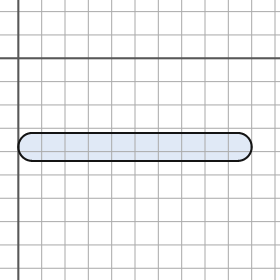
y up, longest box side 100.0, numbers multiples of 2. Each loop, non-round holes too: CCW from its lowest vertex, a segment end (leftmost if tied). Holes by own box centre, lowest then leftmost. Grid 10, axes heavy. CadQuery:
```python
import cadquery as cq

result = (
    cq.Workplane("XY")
    .moveTo(6.0, -44.0)
    .lineTo(94.0, -44.0)
    .threePointArc((100.0, -38.0), (94.0, -32.0))
    .lineTo(6.0, -32.0)
    .threePointArc((0.0, -38.0), (6.0, -44.0))
    .close()
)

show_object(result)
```